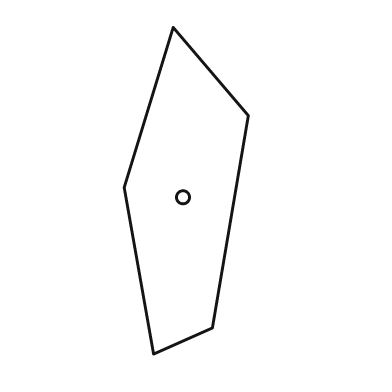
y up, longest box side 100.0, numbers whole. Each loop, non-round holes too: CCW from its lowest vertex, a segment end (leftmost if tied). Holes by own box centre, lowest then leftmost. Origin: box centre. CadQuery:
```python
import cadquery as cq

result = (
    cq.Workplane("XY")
    .moveTo(-10.0, -50.0)
    .lineTo(8.0, -42.0)
    .lineTo(19.0, 23.0)
    .lineTo(-4.0, 50.0)
    .lineTo(-19.0, 1.0)
    .close()
    .moveTo(-1.0, -2.0)
    .circle(2.0)
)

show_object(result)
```